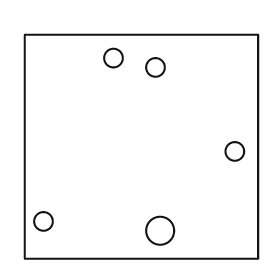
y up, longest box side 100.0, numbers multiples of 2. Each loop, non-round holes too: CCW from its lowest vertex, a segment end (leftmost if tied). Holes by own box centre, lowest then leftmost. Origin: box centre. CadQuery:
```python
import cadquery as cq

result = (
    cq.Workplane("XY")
    .moveTo(-50.0, -48.0)
    .lineTo(50.0, -48.0)
    .lineTo(50.0, 48.0)
    .lineTo(-50.0, 48.0)
    .close()
    .moveTo(8.0, -36.0)
    .circle(6.0)
    .moveTo(-42.0, -32.0)
    .circle(4.0)
    .moveTo(40.0, -2.0)
    .circle(4.0)
    .moveTo(6.0, 34.0)
    .circle(4.0)
    .moveTo(-12.0, 38.0)
    .circle(4.0)
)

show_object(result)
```